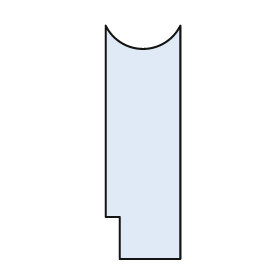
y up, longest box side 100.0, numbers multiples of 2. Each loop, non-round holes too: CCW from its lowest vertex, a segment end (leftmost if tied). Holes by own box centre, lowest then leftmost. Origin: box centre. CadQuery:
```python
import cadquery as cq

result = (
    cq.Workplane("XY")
    .moveTo(-10.0, -50.0)
    .lineTo(16.0, -50.0)
    .lineTo(16.0, 50.0)
    .threePointArc((0.0, 40.0), (-16.0, 50.0))
    .lineTo(-16.0, -32.0)
    .lineTo(-10.0, -32.0)
    .close()
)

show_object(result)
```